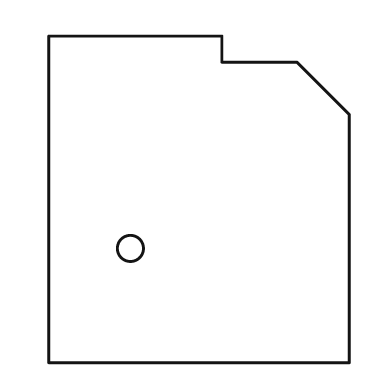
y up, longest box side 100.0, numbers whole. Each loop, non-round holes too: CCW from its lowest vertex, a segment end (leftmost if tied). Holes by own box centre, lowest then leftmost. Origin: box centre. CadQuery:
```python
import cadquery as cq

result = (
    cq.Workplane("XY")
    .moveTo(-46.0, -50.0)
    .lineTo(46.0, -50.0)
    .lineTo(46.0, 26.0)
    .lineTo(30.0, 42.0)
    .lineTo(7.0, 42.0)
    .lineTo(7.0, 50.0)
    .lineTo(-46.0, 50.0)
    .close()
    .moveTo(-21.0, -15.0)
    .circle(4.0)
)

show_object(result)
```